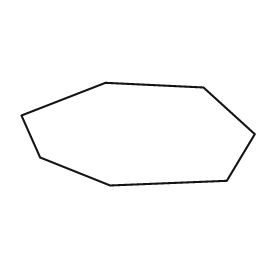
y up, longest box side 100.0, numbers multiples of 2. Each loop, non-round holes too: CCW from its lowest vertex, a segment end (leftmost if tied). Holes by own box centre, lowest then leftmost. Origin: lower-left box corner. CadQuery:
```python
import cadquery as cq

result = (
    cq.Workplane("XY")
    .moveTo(38.0, 0.0)
    .lineTo(88.0, 2.0)
    .lineTo(100.0, 22.0)
    .lineTo(78.0, 42.0)
    .lineTo(36.0, 44.0)
    .lineTo(0.0, 30.0)
    .lineTo(8.0, 12.0)
    .close()
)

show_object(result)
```